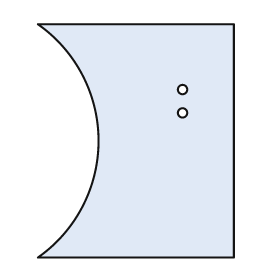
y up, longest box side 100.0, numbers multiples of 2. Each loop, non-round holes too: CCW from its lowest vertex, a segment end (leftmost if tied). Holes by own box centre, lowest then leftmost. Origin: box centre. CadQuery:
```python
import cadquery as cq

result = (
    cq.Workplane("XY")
    .moveTo(-42.0, -50.0)
    .lineTo(42.0, -50.0)
    .lineTo(42.0, 50.0)
    .lineTo(-42.0, 50.0)
    .threePointArc((-16.0, 0.0), (-42.0, -50.0))
    .close()
    .moveTo(20.0, 12.0)
    .circle(2.0)
    .moveTo(20.0, 22.0)
    .circle(2.0)
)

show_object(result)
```